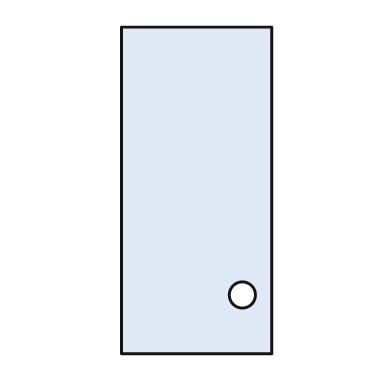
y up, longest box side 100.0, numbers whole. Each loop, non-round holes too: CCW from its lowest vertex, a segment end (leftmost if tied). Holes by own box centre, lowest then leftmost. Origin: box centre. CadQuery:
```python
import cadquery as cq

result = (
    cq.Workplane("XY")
    .moveTo(-23.0, -50.0)
    .lineTo(23.0, -50.0)
    .lineTo(23.0, 50.0)
    .lineTo(-23.0, 50.0)
    .close()
    .moveTo(14.0, -32.0)
    .circle(4.0)
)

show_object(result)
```